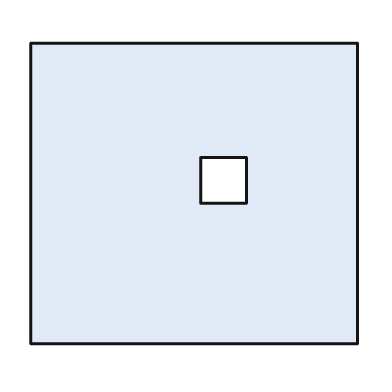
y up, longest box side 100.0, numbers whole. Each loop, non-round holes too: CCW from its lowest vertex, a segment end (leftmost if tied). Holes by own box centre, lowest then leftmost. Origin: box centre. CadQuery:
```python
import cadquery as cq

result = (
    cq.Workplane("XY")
    .moveTo(-50.0, -46.0)
    .lineTo(50.0, -46.0)
    .lineTo(50.0, 46.0)
    .lineTo(-50.0, 46.0)
    .close()
    .moveTo(2.0, -3.0)
    .lineTo(16.0, -3.0)
    .lineTo(16.0, 11.0)
    .lineTo(2.0, 11.0)
    .close()
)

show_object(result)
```